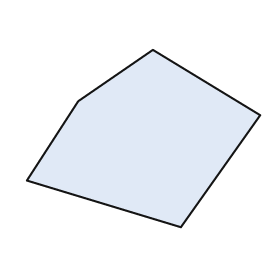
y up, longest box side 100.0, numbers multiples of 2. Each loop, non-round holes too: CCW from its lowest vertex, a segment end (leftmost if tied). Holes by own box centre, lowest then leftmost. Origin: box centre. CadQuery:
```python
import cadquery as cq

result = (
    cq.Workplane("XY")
    .moveTo(16.0, -38.0)
    .lineTo(50.0, 10.0)
    .lineTo(4.0, 38.0)
    .lineTo(-28.0, 16.0)
    .lineTo(-50.0, -18.0)
    .close()
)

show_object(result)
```